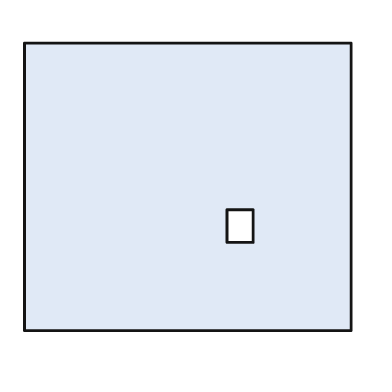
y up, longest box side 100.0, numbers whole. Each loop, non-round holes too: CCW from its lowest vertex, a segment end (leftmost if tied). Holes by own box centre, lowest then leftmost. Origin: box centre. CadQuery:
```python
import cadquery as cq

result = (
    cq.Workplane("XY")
    .moveTo(-50.0, -44.0)
    .lineTo(50.0, -44.0)
    .lineTo(50.0, 44.0)
    .lineTo(-50.0, 44.0)
    .close()
    .moveTo(12.0, -17.0)
    .lineTo(20.0, -17.0)
    .lineTo(20.0, -7.0)
    .lineTo(12.0, -7.0)
    .close()
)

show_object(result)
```